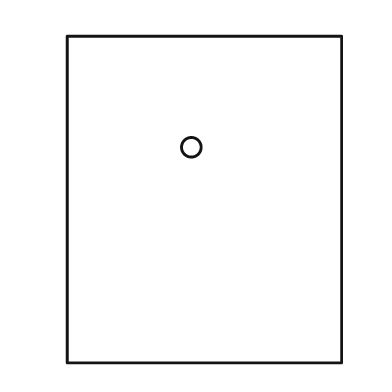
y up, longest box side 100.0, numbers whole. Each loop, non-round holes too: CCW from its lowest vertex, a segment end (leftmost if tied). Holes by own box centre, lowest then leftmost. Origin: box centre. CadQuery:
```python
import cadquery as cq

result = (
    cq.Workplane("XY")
    .moveTo(-42.0, -50.0)
    .lineTo(42.0, -50.0)
    .lineTo(42.0, 50.0)
    .lineTo(-42.0, 50.0)
    .close()
    .moveTo(-4.0, 16.0)
    .circle(3.0)
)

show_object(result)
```